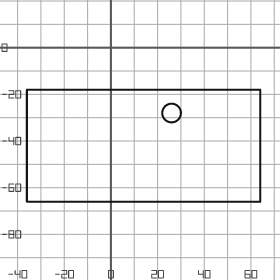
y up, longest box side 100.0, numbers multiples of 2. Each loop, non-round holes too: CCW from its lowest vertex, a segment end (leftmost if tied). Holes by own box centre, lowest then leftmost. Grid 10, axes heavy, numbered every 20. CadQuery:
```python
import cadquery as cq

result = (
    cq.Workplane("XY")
    .moveTo(-36.0, -66.0)
    .lineTo(64.0, -66.0)
    .lineTo(64.0, -18.0)
    .lineTo(-36.0, -18.0)
    .close()
    .moveTo(26.0, -28.0)
    .circle(4.0)
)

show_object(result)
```